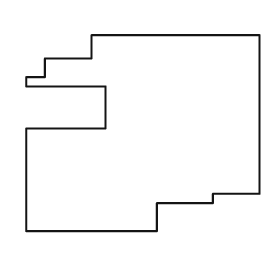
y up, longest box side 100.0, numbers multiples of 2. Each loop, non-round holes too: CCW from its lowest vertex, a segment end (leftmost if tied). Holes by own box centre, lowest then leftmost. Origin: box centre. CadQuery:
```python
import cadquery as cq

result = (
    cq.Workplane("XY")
    .moveTo(-50.0, -42.0)
    .lineTo(6.0, -42.0)
    .lineTo(6.0, -30.0)
    .lineTo(30.0, -30.0)
    .lineTo(30.0, -26.0)
    .lineTo(50.0, -26.0)
    .lineTo(50.0, 42.0)
    .lineTo(-22.0, 42.0)
    .lineTo(-22.0, 32.0)
    .lineTo(-42.0, 32.0)
    .lineTo(-42.0, 24.0)
    .lineTo(-50.0, 24.0)
    .lineTo(-50.0, 20.0)
    .lineTo(-16.0, 20.0)
    .lineTo(-16.0, 2.0)
    .lineTo(-50.0, 2.0)
    .close()
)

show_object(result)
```